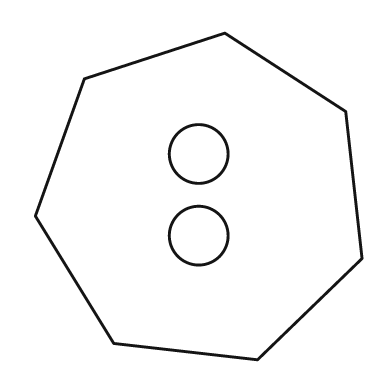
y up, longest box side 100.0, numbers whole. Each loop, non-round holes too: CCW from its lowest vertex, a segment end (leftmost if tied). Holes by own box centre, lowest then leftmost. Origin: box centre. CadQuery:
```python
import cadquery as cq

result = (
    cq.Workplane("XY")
    .moveTo(18.0, -50.0)
    .lineTo(50.0, -19.0)
    .lineTo(45.0, 26.0)
    .lineTo(8.0, 50.0)
    .lineTo(-35.0, 36.0)
    .lineTo(-50.0, -6.0)
    .lineTo(-26.0, -45.0)
    .close()
    .moveTo(0.0, -12.0)
    .circle(9.0)
    .moveTo(0.0, 13.0)
    .circle(9.0)
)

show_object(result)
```